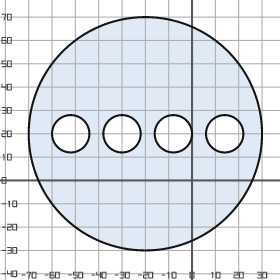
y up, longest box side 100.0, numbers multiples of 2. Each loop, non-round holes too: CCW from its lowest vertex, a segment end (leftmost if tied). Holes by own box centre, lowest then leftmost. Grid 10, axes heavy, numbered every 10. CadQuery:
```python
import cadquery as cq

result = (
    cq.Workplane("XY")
    .moveTo(-20.0, 20.0)
    .circle(50.0)
    .moveTo(-52.0, 20.0)
    .circle(8.0)
    .moveTo(-30.0, 20.0)
    .circle(8.0)
    .moveTo(-8.0, 20.0)
    .circle(8.0)
    .moveTo(14.0, 20.0)
    .circle(8.0)
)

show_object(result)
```